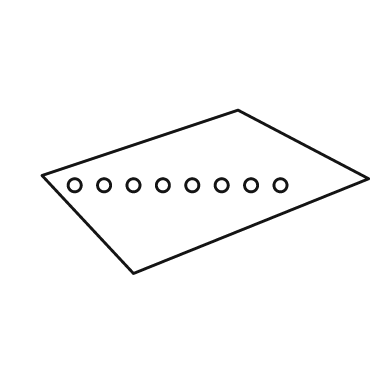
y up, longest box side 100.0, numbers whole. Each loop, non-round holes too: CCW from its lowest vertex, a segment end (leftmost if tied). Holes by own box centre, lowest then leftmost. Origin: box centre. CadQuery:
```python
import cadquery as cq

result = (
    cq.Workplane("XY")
    .moveTo(-22.0, -25.0)
    .lineTo(50.0, 4.0)
    .lineTo(10.0, 25.0)
    .lineTo(-50.0, 5.0)
    .close()
    .moveTo(-40.0, 2.0)
    .circle(2.0)
    .moveTo(-31.0, 2.0)
    .circle(2.0)
    .moveTo(-22.0, 2.0)
    .circle(2.0)
    .moveTo(-13.0, 2.0)
    .circle(2.0)
    .moveTo(-4.0, 2.0)
    .circle(2.0)
    .moveTo(5.0, 2.0)
    .circle(2.0)
    .moveTo(14.0, 2.0)
    .circle(2.0)
    .moveTo(23.0, 2.0)
    .circle(2.0)
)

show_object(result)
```